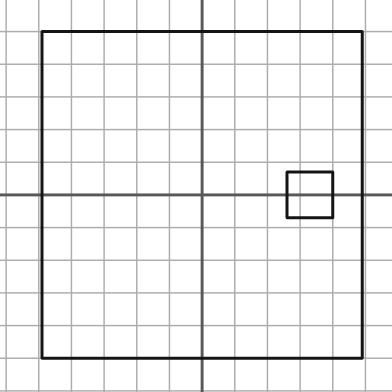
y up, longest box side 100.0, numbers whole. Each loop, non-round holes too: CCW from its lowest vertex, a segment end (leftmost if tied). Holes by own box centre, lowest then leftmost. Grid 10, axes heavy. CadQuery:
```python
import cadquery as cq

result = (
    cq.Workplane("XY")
    .moveTo(-49.0, -50.0)
    .lineTo(49.0, -50.0)
    .lineTo(49.0, 50.0)
    .lineTo(-49.0, 50.0)
    .close()
    .moveTo(26.0, -7.0)
    .lineTo(40.0, -7.0)
    .lineTo(40.0, 7.0)
    .lineTo(26.0, 7.0)
    .close()
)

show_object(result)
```